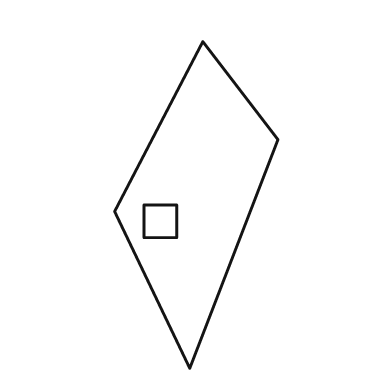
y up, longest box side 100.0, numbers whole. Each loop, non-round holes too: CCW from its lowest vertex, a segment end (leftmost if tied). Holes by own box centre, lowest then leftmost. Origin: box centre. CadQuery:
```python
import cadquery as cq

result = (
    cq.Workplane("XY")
    .moveTo(-2.0, -50.0)
    .lineTo(25.0, 20.0)
    .lineTo(2.0, 50.0)
    .lineTo(-25.0, -2.0)
    .close()
    .moveTo(-16.0, -10.0)
    .lineTo(-6.0, -10.0)
    .lineTo(-6.0, 0.0)
    .lineTo(-16.0, 0.0)
    .close()
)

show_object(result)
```